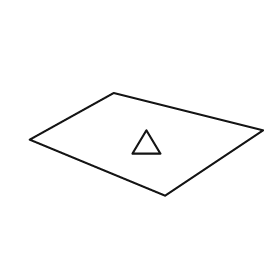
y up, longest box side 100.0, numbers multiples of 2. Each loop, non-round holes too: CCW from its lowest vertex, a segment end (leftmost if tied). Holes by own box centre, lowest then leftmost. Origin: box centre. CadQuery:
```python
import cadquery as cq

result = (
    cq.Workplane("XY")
    .moveTo(8.0, -22.0)
    .lineTo(50.0, 6.0)
    .lineTo(-14.0, 22.0)
    .lineTo(-50.0, 2.0)
    .close()
    .moveTo(-6.0, -4.0)
    .lineTo(6.0, -4.0)
    .lineTo(0.0, 6.0)
    .close()
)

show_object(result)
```